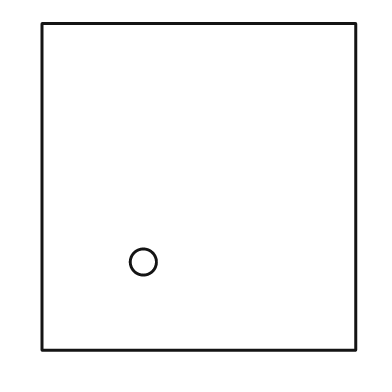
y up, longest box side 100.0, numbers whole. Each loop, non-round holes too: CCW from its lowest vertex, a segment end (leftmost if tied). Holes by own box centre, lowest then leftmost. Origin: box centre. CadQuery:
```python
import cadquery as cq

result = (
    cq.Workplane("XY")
    .moveTo(-48.0, -50.0)
    .lineTo(48.0, -50.0)
    .lineTo(48.0, 50.0)
    .lineTo(-48.0, 50.0)
    .close()
    .moveTo(-17.0, -23.0)
    .circle(4.0)
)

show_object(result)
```